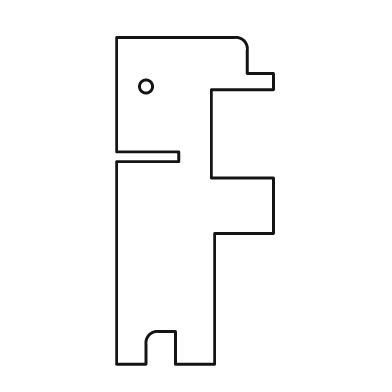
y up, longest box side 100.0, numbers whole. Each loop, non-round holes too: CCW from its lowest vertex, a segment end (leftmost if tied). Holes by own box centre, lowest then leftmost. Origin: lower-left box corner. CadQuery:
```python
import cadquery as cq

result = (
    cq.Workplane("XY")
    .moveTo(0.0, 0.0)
    .lineTo(9.0, 0.0)
    .lineTo(9.0, 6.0)
    .threePointArc((10.0, 9.0), (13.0, 10.0))
    .lineTo(18.0, 10.0)
    .lineTo(18.0, 0.0)
    .lineTo(30.0, 0.0)
    .lineTo(30.0, 40.0)
    .lineTo(48.0, 40.0)
    .lineTo(48.0, 57.0)
    .lineTo(29.0, 57.0)
    .lineTo(29.0, 84.0)
    .lineTo(48.0, 84.0)
    .lineTo(48.0, 89.0)
    .lineTo(40.0, 89.0)
    .lineTo(40.0, 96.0)
    .threePointArc((39.0, 99.0), (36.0, 100.0))
    .lineTo(0.0, 100.0)
    .lineTo(0.0, 65.0)
    .lineTo(19.0, 65.0)
    .lineTo(19.0, 62.0)
    .lineTo(0.0, 62.0)
    .close()
    .moveTo(9.0, 85.0)
    .circle(2.0)
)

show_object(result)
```